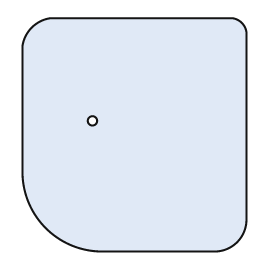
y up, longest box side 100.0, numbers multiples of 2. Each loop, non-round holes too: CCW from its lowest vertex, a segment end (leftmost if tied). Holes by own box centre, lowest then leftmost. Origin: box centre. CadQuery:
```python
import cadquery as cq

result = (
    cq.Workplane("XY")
    .moveTo(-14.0, -50.0)
    .lineTo(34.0, -50.0)
    .threePointArc((44.0, -46.0), (48.0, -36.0))
    .lineTo(48.0, 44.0)
    .threePointArc((46.0, 48.0), (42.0, 50.0))
    .lineTo(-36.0, 50.0)
    .threePointArc((-44.0, 46.0), (-48.0, 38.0))
    .lineTo(-48.0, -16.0)
    .threePointArc((-38.0, -40.0), (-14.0, -50.0))
    .close()
    .moveTo(-18.0, 6.0)
    .circle(2.0)
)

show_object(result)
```